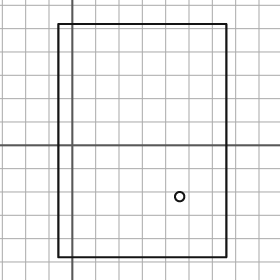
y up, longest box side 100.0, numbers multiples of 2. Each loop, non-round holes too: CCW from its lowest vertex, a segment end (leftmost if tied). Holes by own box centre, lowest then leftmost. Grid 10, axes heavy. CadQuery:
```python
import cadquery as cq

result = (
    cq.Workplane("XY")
    .moveTo(-6.0, -48.0)
    .lineTo(66.0, -48.0)
    .lineTo(66.0, 52.0)
    .lineTo(-6.0, 52.0)
    .close()
    .moveTo(46.0, -22.0)
    .circle(2.0)
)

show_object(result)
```